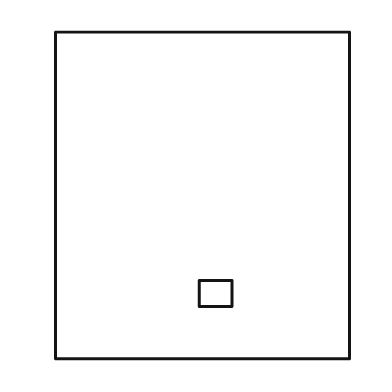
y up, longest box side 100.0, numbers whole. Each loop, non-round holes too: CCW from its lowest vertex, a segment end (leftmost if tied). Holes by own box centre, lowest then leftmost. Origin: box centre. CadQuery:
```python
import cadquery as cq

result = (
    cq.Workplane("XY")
    .moveTo(-45.0, -50.0)
    .lineTo(45.0, -50.0)
    .lineTo(45.0, 50.0)
    .lineTo(-45.0, 50.0)
    .close()
    .moveTo(-1.0, -34.0)
    .lineTo(9.0, -34.0)
    .lineTo(9.0, -26.0)
    .lineTo(-1.0, -26.0)
    .close()
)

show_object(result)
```